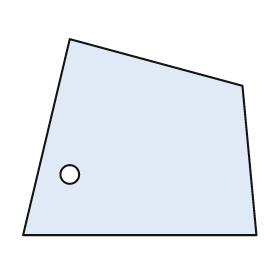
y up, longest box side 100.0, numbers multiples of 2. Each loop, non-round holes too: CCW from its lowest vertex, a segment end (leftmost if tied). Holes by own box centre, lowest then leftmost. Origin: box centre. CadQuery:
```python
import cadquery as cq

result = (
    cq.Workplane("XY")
    .moveTo(-50.0, -42.0)
    .lineTo(50.0, -42.0)
    .lineTo(44.0, 22.0)
    .lineTo(-30.0, 42.0)
    .close()
    .moveTo(-30.0, -16.0)
    .circle(4.0)
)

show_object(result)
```